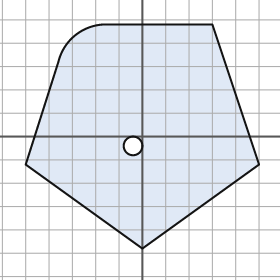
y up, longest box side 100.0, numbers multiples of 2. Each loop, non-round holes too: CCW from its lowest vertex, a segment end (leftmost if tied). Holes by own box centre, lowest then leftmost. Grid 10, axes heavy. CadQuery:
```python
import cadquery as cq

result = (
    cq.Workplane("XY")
    .moveTo(0.0, -48.0)
    .lineTo(50.0, -12.0)
    .lineTo(30.0, 48.0)
    .lineTo(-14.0, 48.0)
    .threePointArc((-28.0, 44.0), (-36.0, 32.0))
    .lineTo(-50.0, -12.0)
    .close()
    .moveTo(-4.0, -4.0)
    .circle(4.0)
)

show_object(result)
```